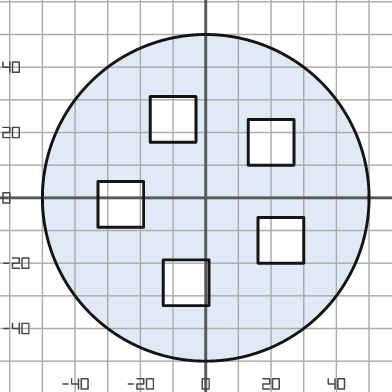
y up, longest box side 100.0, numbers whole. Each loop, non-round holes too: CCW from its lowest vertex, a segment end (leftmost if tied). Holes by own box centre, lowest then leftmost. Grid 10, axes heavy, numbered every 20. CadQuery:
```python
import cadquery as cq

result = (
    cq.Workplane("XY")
    .moveTo(0.0, 0.0)
    .circle(50.0)
    .moveTo(-13.0, -33.0)
    .lineTo(1.0, -33.0)
    .lineTo(1.0, -19.0)
    .lineTo(-13.0, -19.0)
    .close()
    .moveTo(16.0, -20.0)
    .lineTo(30.0, -20.0)
    .lineTo(30.0, -6.0)
    .lineTo(16.0, -6.0)
    .close()
    .moveTo(-33.0, -9.0)
    .lineTo(-19.0, -9.0)
    .lineTo(-19.0, 5.0)
    .lineTo(-33.0, 5.0)
    .close()
    .moveTo(13.0, 10.0)
    .lineTo(27.0, 10.0)
    .lineTo(27.0, 24.0)
    .lineTo(13.0, 24.0)
    .close()
    .moveTo(-17.0, 17.0)
    .lineTo(-3.0, 17.0)
    .lineTo(-3.0, 31.0)
    .lineTo(-17.0, 31.0)
    .close()
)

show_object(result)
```